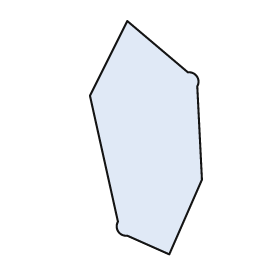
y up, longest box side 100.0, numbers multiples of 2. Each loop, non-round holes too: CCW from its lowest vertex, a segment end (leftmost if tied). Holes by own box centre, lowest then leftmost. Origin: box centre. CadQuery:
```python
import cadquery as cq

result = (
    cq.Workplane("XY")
    .moveTo(10.0, -50.0)
    .lineTo(24.0, -18.0)
    .lineTo(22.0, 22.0)
    .threePointArc((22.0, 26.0), (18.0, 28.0))
    .lineTo(-8.0, 50.0)
    .lineTo(-24.0, 18.0)
    .lineTo(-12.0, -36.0)
    .threePointArc((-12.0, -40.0), (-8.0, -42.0))
    .close()
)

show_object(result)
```